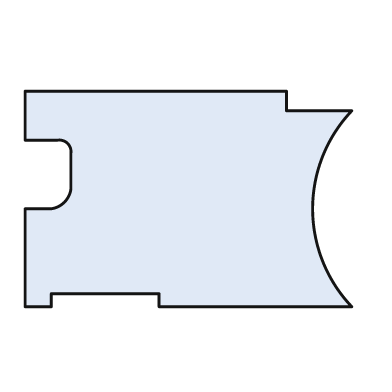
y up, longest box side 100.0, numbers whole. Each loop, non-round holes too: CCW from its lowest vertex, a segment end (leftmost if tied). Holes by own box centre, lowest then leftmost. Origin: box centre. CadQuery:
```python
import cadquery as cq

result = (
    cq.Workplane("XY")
    .moveTo(-50.0, -33.0)
    .lineTo(-42.0, -33.0)
    .lineTo(-42.0, -29.0)
    .lineTo(-9.0, -29.0)
    .lineTo(-9.0, -33.0)
    .lineTo(50.0, -33.0)
    .threePointArc((38.0, -3.0), (50.0, 27.0))
    .lineTo(30.0, 27.0)
    .lineTo(30.0, 33.0)
    .lineTo(-50.0, 33.0)
    .lineTo(-50.0, 18.0)
    .lineTo(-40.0, 18.0)
    .threePointArc((-37.0, 17.0), (-36.0, 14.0))
    .lineTo(-36.0, 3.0)
    .threePointArc((-38.0, -1.0), (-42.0, -3.0))
    .lineTo(-50.0, -3.0)
    .close()
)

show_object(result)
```